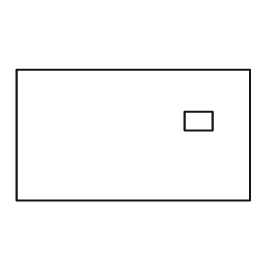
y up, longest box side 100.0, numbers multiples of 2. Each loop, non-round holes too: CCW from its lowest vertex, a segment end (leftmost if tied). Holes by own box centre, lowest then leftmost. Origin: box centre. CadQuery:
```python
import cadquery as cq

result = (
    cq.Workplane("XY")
    .moveTo(-50.0, -28.0)
    .lineTo(50.0, -28.0)
    .lineTo(50.0, 28.0)
    .lineTo(-50.0, 28.0)
    .close()
    .moveTo(22.0, 2.0)
    .lineTo(34.0, 2.0)
    .lineTo(34.0, 10.0)
    .lineTo(22.0, 10.0)
    .close()
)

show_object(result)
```